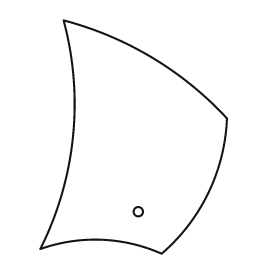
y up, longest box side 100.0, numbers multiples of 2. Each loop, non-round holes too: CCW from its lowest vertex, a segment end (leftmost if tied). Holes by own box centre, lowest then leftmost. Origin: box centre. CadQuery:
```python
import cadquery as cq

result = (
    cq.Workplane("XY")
    .moveTo(12.0, -50.0)
    .threePointArc((32.0, -24.0), (40.0, 8.0))
    .threePointArc((8.0, 34.0), (-30.0, 50.0))
    .threePointArc((-26.0, 0.0), (-40.0, -48.0))
    .threePointArc((-14.0, -44.0), (12.0, -50.0))
    .close()
    .moveTo(2.0, -32.0)
    .circle(2.0)
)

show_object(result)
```